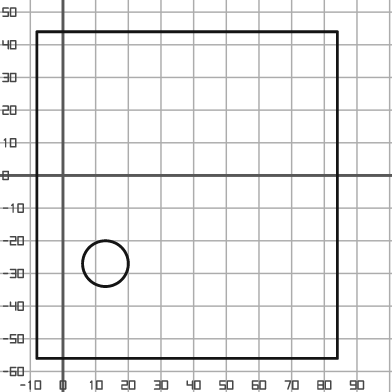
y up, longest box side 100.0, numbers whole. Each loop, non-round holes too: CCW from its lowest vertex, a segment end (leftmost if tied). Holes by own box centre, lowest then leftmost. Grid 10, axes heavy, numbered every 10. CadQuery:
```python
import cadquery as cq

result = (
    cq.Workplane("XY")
    .moveTo(-8.0, -56.0)
    .lineTo(84.0, -56.0)
    .lineTo(84.0, 44.0)
    .lineTo(-8.0, 44.0)
    .close()
    .moveTo(13.0, -27.0)
    .circle(7.0)
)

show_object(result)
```